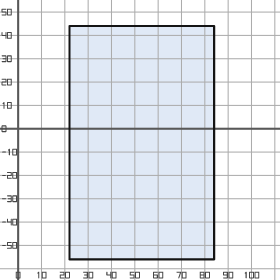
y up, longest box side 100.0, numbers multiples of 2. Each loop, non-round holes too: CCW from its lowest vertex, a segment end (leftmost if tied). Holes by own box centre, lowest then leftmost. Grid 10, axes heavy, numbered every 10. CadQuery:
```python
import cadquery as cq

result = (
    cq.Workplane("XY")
    .moveTo(22.0, -56.0)
    .lineTo(84.0, -56.0)
    .lineTo(84.0, 44.0)
    .lineTo(22.0, 44.0)
    .close()
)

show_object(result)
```